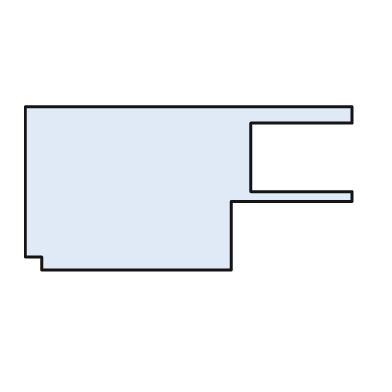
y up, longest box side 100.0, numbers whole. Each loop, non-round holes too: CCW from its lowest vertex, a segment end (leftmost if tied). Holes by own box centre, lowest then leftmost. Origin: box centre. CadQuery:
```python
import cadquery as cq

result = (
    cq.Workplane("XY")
    .moveTo(-45.0, -25.0)
    .lineTo(13.0, -25.0)
    .lineTo(13.0, -4.0)
    .lineTo(50.0, -4.0)
    .lineTo(50.0, -1.0)
    .lineTo(19.0, -1.0)
    .lineTo(19.0, 20.0)
    .lineTo(50.0, 20.0)
    .lineTo(50.0, 25.0)
    .lineTo(-50.0, 25.0)
    .lineTo(-50.0, -21.0)
    .lineTo(-45.0, -21.0)
    .close()
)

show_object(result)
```